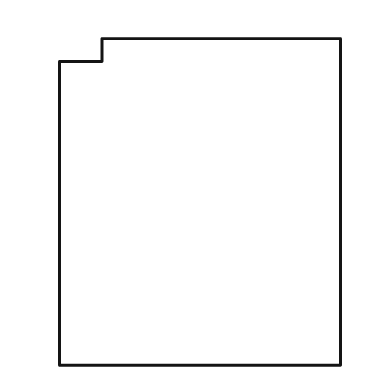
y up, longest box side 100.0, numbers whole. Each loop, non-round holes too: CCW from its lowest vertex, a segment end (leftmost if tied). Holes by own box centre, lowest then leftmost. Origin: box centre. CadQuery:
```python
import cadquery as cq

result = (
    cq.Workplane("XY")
    .moveTo(-43.0, -50.0)
    .lineTo(43.0, -50.0)
    .lineTo(43.0, 50.0)
    .lineTo(-30.0, 50.0)
    .lineTo(-30.0, 43.0)
    .lineTo(-43.0, 43.0)
    .close()
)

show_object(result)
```